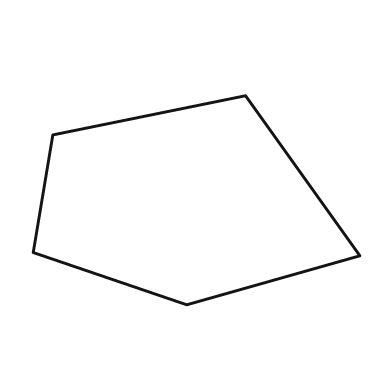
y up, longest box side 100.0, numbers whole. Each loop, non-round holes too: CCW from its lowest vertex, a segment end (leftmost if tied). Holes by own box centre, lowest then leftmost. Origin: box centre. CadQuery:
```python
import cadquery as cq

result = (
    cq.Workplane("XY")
    .moveTo(-3.0, -32.0)
    .lineTo(50.0, -17.0)
    .lineTo(15.0, 32.0)
    .lineTo(-44.0, 20.0)
    .lineTo(-50.0, -16.0)
    .close()
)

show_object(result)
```